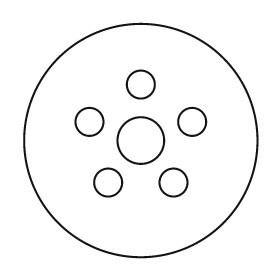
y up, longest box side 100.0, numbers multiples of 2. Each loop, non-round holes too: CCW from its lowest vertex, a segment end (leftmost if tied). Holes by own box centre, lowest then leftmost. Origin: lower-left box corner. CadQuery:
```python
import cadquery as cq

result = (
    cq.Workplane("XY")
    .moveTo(50.0, 50.0)
    .circle(50.0)
    .moveTo(36.0, 32.0)
    .circle(6.0)
    .moveTo(64.0, 32.0)
    .circle(6.0)
    .moveTo(50.0, 50.0)
    .circle(10.0)
    .moveTo(28.0, 58.0)
    .circle(6.0)
    .moveTo(72.0, 58.0)
    .circle(6.0)
    .moveTo(50.0, 74.0)
    .circle(6.0)
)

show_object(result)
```